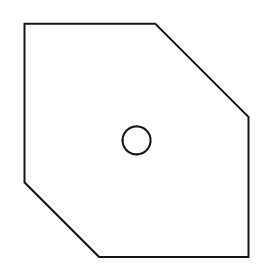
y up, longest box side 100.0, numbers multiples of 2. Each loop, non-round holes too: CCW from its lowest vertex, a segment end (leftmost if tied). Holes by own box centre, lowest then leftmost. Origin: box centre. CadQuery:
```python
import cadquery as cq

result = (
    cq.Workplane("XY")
    .moveTo(-16.0, -50.0)
    .lineTo(48.0, -50.0)
    .lineTo(48.0, 10.0)
    .lineTo(8.0, 50.0)
    .lineTo(-48.0, 50.0)
    .lineTo(-48.0, -18.0)
    .close()
    .moveTo(0.0, 0.0)
    .circle(6.0)
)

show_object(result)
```